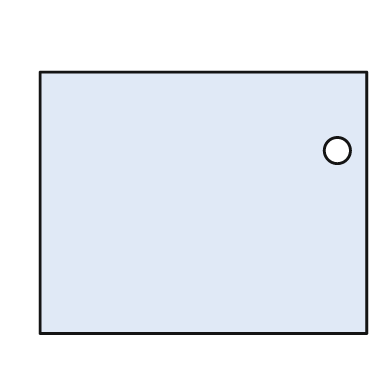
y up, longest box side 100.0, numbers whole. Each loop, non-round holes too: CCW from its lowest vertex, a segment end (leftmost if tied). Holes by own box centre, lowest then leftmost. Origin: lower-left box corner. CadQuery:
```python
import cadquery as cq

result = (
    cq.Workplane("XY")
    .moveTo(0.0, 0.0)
    .lineTo(100.0, 0.0)
    .lineTo(100.0, 80.0)
    .lineTo(0.0, 80.0)
    .close()
    .moveTo(91.0, 56.0)
    .circle(4.0)
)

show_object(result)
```